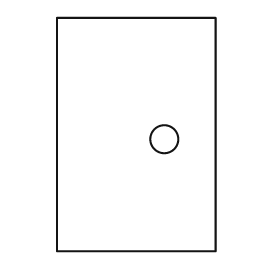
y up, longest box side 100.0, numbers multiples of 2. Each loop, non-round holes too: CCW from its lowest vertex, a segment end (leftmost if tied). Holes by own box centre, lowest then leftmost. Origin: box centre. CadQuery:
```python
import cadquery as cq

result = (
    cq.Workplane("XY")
    .moveTo(-34.0, -50.0)
    .lineTo(34.0, -50.0)
    .lineTo(34.0, 50.0)
    .lineTo(-34.0, 50.0)
    .close()
    .moveTo(12.0, -2.0)
    .circle(6.0)
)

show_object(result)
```